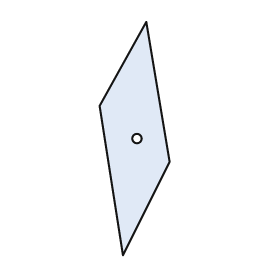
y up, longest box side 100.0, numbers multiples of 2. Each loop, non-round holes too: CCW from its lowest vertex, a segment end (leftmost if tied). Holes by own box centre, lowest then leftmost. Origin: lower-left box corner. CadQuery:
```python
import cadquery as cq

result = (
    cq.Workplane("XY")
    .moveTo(10.0, 0.0)
    .lineTo(30.0, 40.0)
    .lineTo(20.0, 100.0)
    .lineTo(0.0, 64.0)
    .close()
    .moveTo(16.0, 50.0)
    .circle(2.0)
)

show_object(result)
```